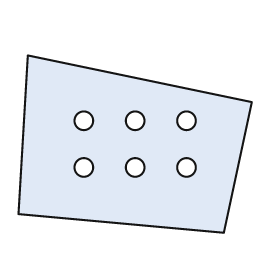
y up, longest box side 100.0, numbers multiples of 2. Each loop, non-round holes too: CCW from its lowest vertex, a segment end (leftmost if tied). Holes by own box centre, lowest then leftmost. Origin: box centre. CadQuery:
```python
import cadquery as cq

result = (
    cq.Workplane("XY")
    .moveTo(38.0, -38.0)
    .lineTo(50.0, 18.0)
    .lineTo(-46.0, 38.0)
    .lineTo(-50.0, -30.0)
    .close()
    .moveTo(-22.0, -10.0)
    .circle(4.0)
    .moveTo(0.0, -10.0)
    .circle(4.0)
    .moveTo(22.0, -10.0)
    .circle(4.0)
    .moveTo(-22.0, 10.0)
    .circle(4.0)
    .moveTo(0.0, 10.0)
    .circle(4.0)
    .moveTo(22.0, 10.0)
    .circle(4.0)
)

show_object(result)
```